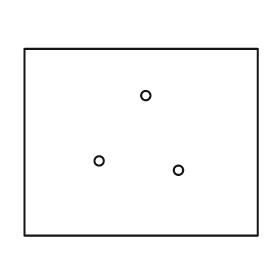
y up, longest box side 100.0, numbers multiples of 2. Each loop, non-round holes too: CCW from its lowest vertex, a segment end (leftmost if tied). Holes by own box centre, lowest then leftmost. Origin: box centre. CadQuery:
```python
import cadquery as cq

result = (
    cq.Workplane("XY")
    .moveTo(-50.0, -40.0)
    .lineTo(50.0, -40.0)
    .lineTo(50.0, 40.0)
    .lineTo(-50.0, 40.0)
    .close()
    .moveTo(16.0, -12.0)
    .circle(2.0)
    .moveTo(-18.0, -8.0)
    .circle(2.0)
    .moveTo(2.0, 20.0)
    .circle(2.0)
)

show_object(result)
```